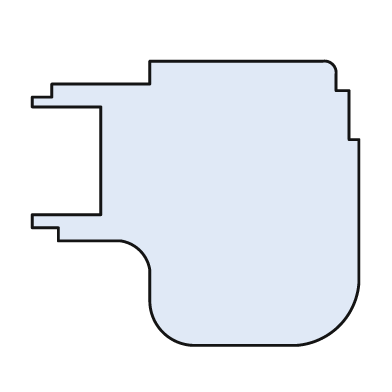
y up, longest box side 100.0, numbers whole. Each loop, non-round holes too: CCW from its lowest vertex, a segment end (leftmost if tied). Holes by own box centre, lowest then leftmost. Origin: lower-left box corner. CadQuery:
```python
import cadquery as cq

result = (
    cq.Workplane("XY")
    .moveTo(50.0, 0.0)
    .lineTo(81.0, 0.0)
    .threePointArc((94.0, 6.0), (100.0, 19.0))
    .lineTo(100.0, 63.0)
    .lineTo(97.0, 63.0)
    .lineTo(97.0, 78.0)
    .lineTo(93.0, 78.0)
    .lineTo(93.0, 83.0)
    .threePointArc((92.0, 86.0), (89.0, 87.0))
    .lineTo(36.0, 87.0)
    .lineTo(36.0, 80.0)
    .lineTo(6.0, 80.0)
    .lineTo(6.0, 76.0)
    .lineTo(0.0, 76.0)
    .lineTo(0.0, 73.0)
    .lineTo(21.0, 73.0)
    .lineTo(21.0, 40.0)
    .lineTo(0.0, 40.0)
    .lineTo(0.0, 36.0)
    .lineTo(8.0, 36.0)
    .lineTo(8.0, 32.0)
    .lineTo(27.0, 32.0)
    .threePointArc((33.0, 29.0), (36.0, 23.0))
    .lineTo(36.0, 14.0)
    .threePointArc((40.0, 4.0), (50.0, 0.0))
    .close()
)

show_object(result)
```